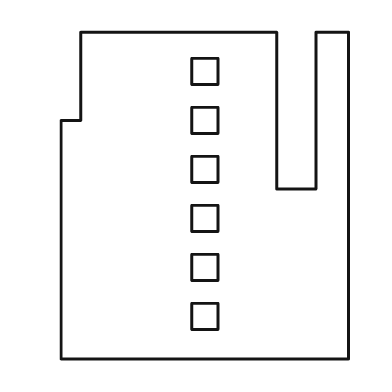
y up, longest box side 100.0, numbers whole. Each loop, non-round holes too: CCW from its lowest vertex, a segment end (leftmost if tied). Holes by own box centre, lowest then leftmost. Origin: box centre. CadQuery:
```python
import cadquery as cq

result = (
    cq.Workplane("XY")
    .moveTo(-44.0, -50.0)
    .lineTo(44.0, -50.0)
    .lineTo(44.0, 50.0)
    .lineTo(34.0, 50.0)
    .lineTo(34.0, 2.0)
    .lineTo(22.0, 2.0)
    .lineTo(22.0, 50.0)
    .lineTo(-38.0, 50.0)
    .lineTo(-38.0, 23.0)
    .lineTo(-44.0, 23.0)
    .close()
    .moveTo(-4.0, -41.0)
    .lineTo(4.0, -41.0)
    .lineTo(4.0, -33.0)
    .lineTo(-4.0, -33.0)
    .close()
    .moveTo(-4.0, -26.0)
    .lineTo(4.0, -26.0)
    .lineTo(4.0, -18.0)
    .lineTo(-4.0, -18.0)
    .close()
    .moveTo(-4.0, -11.0)
    .lineTo(4.0, -11.0)
    .lineTo(4.0, -3.0)
    .lineTo(-4.0, -3.0)
    .close()
    .moveTo(-4.0, 4.0)
    .lineTo(4.0, 4.0)
    .lineTo(4.0, 12.0)
    .lineTo(-4.0, 12.0)
    .close()
    .moveTo(-4.0, 19.0)
    .lineTo(4.0, 19.0)
    .lineTo(4.0, 27.0)
    .lineTo(-4.0, 27.0)
    .close()
    .moveTo(-4.0, 34.0)
    .lineTo(4.0, 34.0)
    .lineTo(4.0, 42.0)
    .lineTo(-4.0, 42.0)
    .close()
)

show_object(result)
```